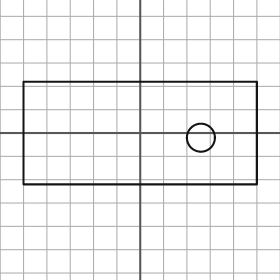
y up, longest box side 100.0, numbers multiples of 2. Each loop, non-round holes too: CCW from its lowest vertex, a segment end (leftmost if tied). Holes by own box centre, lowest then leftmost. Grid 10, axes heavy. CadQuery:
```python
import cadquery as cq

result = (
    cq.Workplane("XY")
    .moveTo(-50.0, -22.0)
    .lineTo(50.0, -22.0)
    .lineTo(50.0, 22.0)
    .lineTo(-50.0, 22.0)
    .close()
    .moveTo(26.0, -2.0)
    .circle(6.0)
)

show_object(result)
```